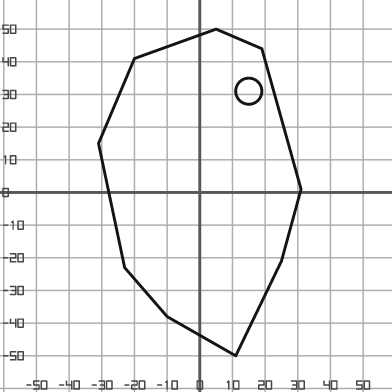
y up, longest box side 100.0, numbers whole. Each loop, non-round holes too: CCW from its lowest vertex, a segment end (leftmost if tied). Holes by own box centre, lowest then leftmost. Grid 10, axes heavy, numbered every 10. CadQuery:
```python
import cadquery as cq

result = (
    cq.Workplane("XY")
    .moveTo(11.0, -50.0)
    .lineTo(25.0, -21.0)
    .lineTo(31.0, 1.0)
    .lineTo(19.0, 44.0)
    .lineTo(5.0, 50.0)
    .lineTo(-20.0, 41.0)
    .lineTo(-31.0, 15.0)
    .lineTo(-23.0, -23.0)
    .lineTo(-10.0, -38.0)
    .close()
    .moveTo(15.0, 31.0)
    .circle(4.0)
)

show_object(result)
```